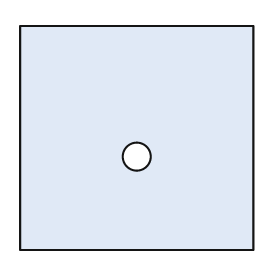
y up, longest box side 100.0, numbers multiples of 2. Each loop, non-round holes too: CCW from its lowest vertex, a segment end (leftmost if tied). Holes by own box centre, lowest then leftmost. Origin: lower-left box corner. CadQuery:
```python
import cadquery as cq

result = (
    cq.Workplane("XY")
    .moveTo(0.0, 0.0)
    .lineTo(100.0, 0.0)
    .lineTo(100.0, 96.0)
    .lineTo(0.0, 96.0)
    .close()
    .moveTo(50.0, 40.0)
    .circle(6.0)
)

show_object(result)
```